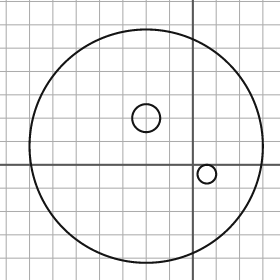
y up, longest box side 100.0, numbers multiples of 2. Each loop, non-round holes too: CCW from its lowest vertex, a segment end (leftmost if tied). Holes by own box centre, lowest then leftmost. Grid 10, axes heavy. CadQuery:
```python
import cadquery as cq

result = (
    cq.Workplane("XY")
    .moveTo(-20.0, 8.0)
    .circle(50.0)
    .moveTo(6.0, -4.0)
    .circle(4.0)
    .moveTo(-20.0, 20.0)
    .circle(6.0)
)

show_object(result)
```